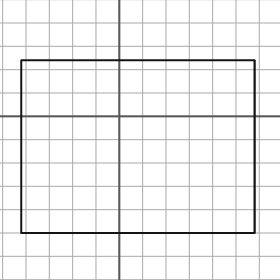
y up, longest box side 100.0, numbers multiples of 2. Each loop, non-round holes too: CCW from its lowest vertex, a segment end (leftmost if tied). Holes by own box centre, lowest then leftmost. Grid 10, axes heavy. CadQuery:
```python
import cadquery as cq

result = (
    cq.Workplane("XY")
    .moveTo(-42.0, -50.0)
    .lineTo(58.0, -50.0)
    .lineTo(58.0, 24.0)
    .lineTo(-42.0, 24.0)
    .close()
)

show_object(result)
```